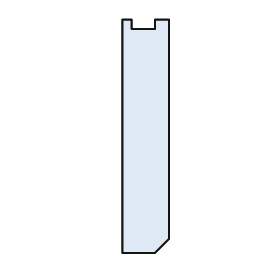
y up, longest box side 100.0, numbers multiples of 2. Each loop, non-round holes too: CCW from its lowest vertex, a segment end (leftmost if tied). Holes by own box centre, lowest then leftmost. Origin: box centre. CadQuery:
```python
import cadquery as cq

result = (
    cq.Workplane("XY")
    .moveTo(-10.0, -50.0)
    .lineTo(4.0, -50.0)
    .lineTo(10.0, -44.0)
    .lineTo(10.0, 50.0)
    .lineTo(4.0, 50.0)
    .lineTo(4.0, 46.0)
    .lineTo(-6.0, 46.0)
    .lineTo(-6.0, 50.0)
    .lineTo(-10.0, 50.0)
    .close()
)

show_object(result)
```